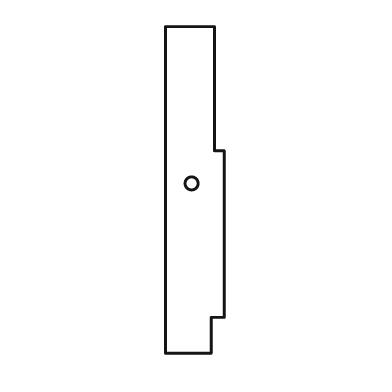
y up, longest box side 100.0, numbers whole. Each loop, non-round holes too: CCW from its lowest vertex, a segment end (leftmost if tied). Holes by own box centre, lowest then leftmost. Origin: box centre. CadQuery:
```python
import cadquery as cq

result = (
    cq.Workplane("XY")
    .moveTo(-9.0, -50.0)
    .lineTo(5.0, -50.0)
    .lineTo(5.0, -39.0)
    .lineTo(9.0, -39.0)
    .lineTo(9.0, 12.0)
    .lineTo(6.0, 12.0)
    .lineTo(6.0, 50.0)
    .lineTo(-9.0, 50.0)
    .close()
    .moveTo(-1.0, 2.0)
    .circle(2.0)
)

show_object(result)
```